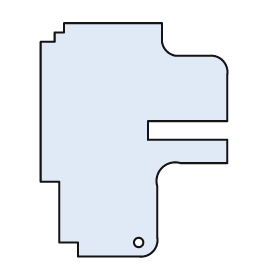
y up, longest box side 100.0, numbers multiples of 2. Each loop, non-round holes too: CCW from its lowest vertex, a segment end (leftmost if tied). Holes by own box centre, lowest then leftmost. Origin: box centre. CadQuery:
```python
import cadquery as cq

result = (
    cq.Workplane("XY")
    .moveTo(-24.0, -50.0)
    .lineTo(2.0, -50.0)
    .threePointArc((8.0, -48.0), (10.0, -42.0))
    .lineTo(10.0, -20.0)
    .threePointArc((12.0, -12.0), (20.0, -10.0))
    .lineTo(40.0, -10.0)
    .lineTo(40.0, 0.0)
    .lineTo(6.0, 0.0)
    .lineTo(6.0, 8.0)
    .lineTo(40.0, 8.0)
    .lineTo(40.0, 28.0)
    .threePointArc((38.0, 34.0), (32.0, 36.0))
    .lineTo(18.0, 36.0)
    .threePointArc((14.0, 38.0), (12.0, 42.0))
    .lineTo(12.0, 50.0)
    .lineTo(-30.0, 50.0)
    .lineTo(-30.0, 46.0)
    .lineTo(-34.0, 46.0)
    .lineTo(-34.0, 42.0)
    .lineTo(-40.0, 42.0)
    .lineTo(-40.0, -18.0)
    .lineTo(-32.0, -18.0)
    .lineTo(-32.0, -44.0)
    .lineTo(-24.0, -44.0)
    .close()
    .moveTo(2.0, -44.0)
    .circle(2.0)
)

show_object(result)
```